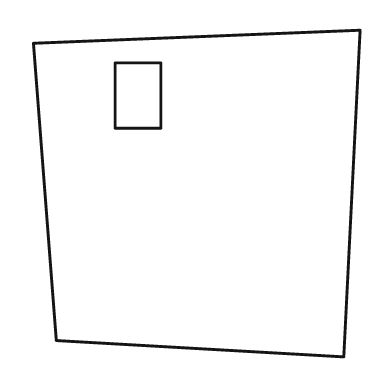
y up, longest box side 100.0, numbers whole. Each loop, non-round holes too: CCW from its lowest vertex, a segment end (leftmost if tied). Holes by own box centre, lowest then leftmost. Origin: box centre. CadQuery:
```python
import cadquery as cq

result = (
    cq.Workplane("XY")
    .moveTo(45.0, -50.0)
    .lineTo(50.0, 50.0)
    .lineTo(-50.0, 46.0)
    .lineTo(-43.0, -45.0)
    .close()
    .moveTo(-25.0, 20.0)
    .lineTo(-11.0, 20.0)
    .lineTo(-11.0, 40.0)
    .lineTo(-25.0, 40.0)
    .close()
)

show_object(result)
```